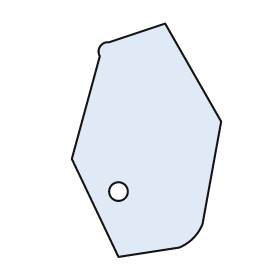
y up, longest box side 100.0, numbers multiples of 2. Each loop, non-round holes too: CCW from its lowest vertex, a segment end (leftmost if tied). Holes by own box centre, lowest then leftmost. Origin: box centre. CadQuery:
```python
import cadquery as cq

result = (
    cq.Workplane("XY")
    .moveTo(-12.0, -50.0)
    .lineTo(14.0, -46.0)
    .threePointArc((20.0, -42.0), (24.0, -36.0))
    .lineTo(32.0, 8.0)
    .lineTo(8.0, 50.0)
    .lineTo(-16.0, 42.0)
    .threePointArc((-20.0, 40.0), (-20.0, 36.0))
    .lineTo(-32.0, -8.0)
    .close()
    .moveTo(-12.0, -22.0)
    .circle(4.0)
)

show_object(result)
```